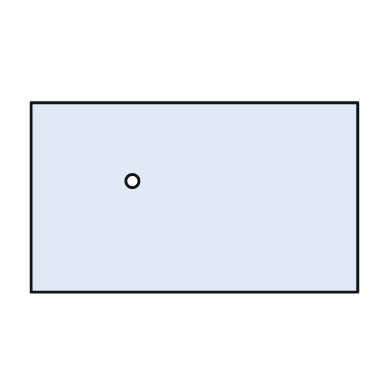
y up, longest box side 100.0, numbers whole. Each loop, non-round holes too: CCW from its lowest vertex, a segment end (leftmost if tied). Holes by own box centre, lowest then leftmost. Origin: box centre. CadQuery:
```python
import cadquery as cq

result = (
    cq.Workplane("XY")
    .moveTo(-50.0, -29.0)
    .lineTo(50.0, -29.0)
    .lineTo(50.0, 29.0)
    .lineTo(-50.0, 29.0)
    .close()
    .moveTo(-19.0, 5.0)
    .circle(2.0)
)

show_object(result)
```